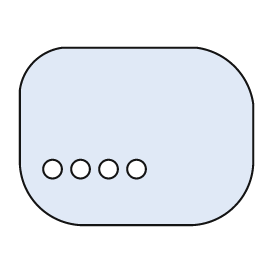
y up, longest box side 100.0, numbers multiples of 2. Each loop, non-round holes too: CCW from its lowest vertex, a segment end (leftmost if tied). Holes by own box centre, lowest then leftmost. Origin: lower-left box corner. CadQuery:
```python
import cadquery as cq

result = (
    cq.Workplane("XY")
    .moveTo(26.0, 0.0)
    .lineTo(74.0, 0.0)
    .threePointArc((92.0, 8.0), (100.0, 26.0))
    .lineTo(100.0, 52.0)
    .threePointArc((92.0, 68.0), (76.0, 76.0))
    .lineTo(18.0, 76.0)
    .threePointArc((6.0, 70.0), (0.0, 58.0))
    .lineTo(0.0, 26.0)
    .threePointArc((8.0, 8.0), (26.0, 0.0))
    .close()
    .moveTo(14.0, 24.0)
    .circle(4.0)
    .moveTo(26.0, 24.0)
    .circle(4.0)
    .moveTo(38.0, 24.0)
    .circle(4.0)
    .moveTo(50.0, 24.0)
    .circle(4.0)
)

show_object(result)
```